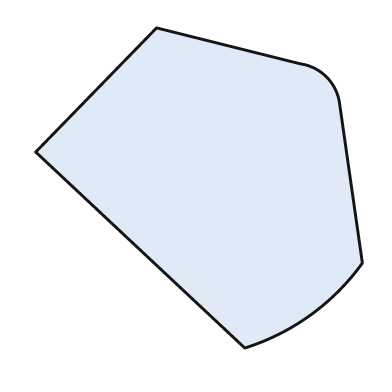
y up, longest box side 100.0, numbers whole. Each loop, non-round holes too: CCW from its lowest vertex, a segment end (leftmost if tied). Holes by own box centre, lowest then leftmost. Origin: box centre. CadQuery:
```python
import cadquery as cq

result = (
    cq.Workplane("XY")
    .moveTo(14.0, -49.0)
    .threePointArc((34.0, -39.0), (50.0, -23.0))
    .lineTo(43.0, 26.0)
    .threePointArc((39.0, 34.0), (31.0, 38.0))
    .lineTo(-13.0, 49.0)
    .lineTo(-50.0, 11.0)
    .close()
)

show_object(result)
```